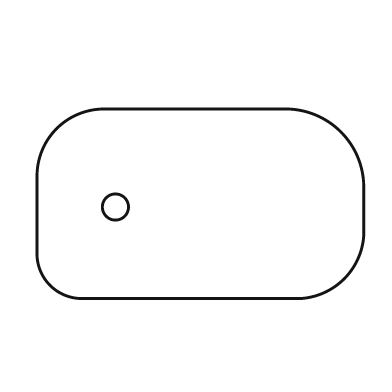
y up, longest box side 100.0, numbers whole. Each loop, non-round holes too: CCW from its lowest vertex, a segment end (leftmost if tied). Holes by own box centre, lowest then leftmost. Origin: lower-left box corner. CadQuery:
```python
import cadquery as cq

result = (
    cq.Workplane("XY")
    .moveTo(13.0, 0.0)
    .lineTo(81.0, 0.0)
    .threePointArc((94.0, 6.0), (100.0, 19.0))
    .lineTo(100.0, 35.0)
    .threePointArc((93.0, 51.0), (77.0, 58.0))
    .lineTo(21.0, 58.0)
    .threePointArc((6.0, 52.0), (0.0, 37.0))
    .lineTo(0.0, 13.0)
    .threePointArc((4.0, 4.0), (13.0, 0.0))
    .close()
    .moveTo(24.0, 28.0)
    .circle(4.0)
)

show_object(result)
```